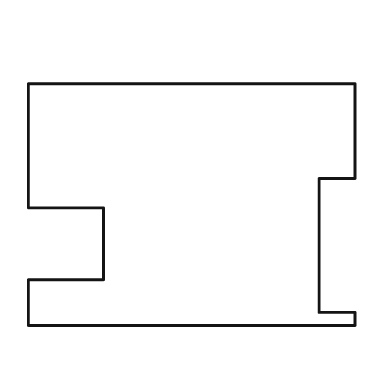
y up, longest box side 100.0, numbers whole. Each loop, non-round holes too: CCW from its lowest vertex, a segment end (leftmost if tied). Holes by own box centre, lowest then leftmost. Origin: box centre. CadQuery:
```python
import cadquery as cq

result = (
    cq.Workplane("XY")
    .moveTo(-50.0, -37.0)
    .lineTo(50.0, -37.0)
    .lineTo(50.0, -33.0)
    .lineTo(39.0, -33.0)
    .lineTo(39.0, 8.0)
    .lineTo(50.0, 8.0)
    .lineTo(50.0, 37.0)
    .lineTo(-50.0, 37.0)
    .lineTo(-50.0, -1.0)
    .lineTo(-27.0, -1.0)
    .lineTo(-27.0, -23.0)
    .lineTo(-50.0, -23.0)
    .close()
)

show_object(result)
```